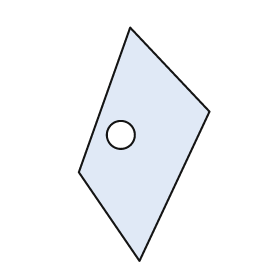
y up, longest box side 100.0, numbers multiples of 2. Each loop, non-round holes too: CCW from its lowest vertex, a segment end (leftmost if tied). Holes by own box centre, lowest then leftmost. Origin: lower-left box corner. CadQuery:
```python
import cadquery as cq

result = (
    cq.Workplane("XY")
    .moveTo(26.0, 0.0)
    .lineTo(56.0, 64.0)
    .lineTo(22.0, 100.0)
    .lineTo(0.0, 38.0)
    .close()
    .moveTo(18.0, 54.0)
    .circle(6.0)
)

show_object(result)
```